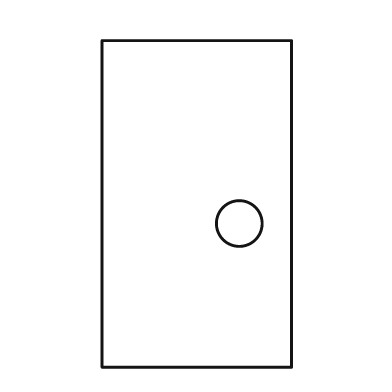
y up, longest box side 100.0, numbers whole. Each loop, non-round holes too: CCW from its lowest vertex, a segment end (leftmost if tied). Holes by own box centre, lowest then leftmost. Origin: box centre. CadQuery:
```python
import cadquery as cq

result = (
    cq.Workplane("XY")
    .moveTo(-29.0, -50.0)
    .lineTo(29.0, -50.0)
    .lineTo(29.0, 50.0)
    .lineTo(-29.0, 50.0)
    .close()
    .moveTo(13.0, -6.0)
    .circle(7.0)
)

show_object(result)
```